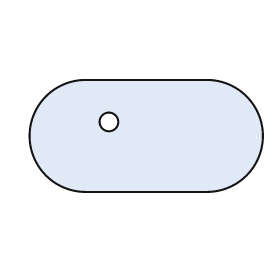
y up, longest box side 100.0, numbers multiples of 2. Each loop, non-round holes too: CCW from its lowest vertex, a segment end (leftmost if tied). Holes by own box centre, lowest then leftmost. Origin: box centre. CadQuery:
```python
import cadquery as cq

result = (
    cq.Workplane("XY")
    .moveTo(-26.0, -24.0)
    .lineTo(26.0, -24.0)
    .threePointArc((50.0, 0.0), (26.0, 24.0))
    .lineTo(-26.0, 24.0)
    .threePointArc((-50.0, 0.0), (-26.0, -24.0))
    .close()
    .moveTo(-16.0, 6.0)
    .circle(4.0)
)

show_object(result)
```